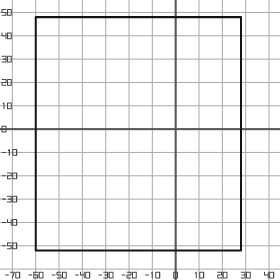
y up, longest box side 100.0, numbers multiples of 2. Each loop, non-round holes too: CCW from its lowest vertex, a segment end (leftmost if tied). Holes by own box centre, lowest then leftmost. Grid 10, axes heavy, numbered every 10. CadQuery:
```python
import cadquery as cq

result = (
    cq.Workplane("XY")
    .moveTo(-60.0, -52.0)
    .lineTo(28.0, -52.0)
    .lineTo(28.0, 48.0)
    .lineTo(-60.0, 48.0)
    .close()
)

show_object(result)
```